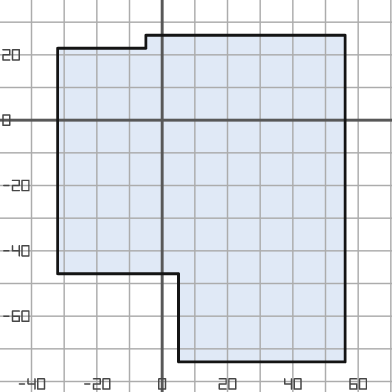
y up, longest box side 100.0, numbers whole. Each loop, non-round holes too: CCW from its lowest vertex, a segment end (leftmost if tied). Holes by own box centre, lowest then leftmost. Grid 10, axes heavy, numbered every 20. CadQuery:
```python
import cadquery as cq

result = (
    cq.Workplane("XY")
    .moveTo(5.0, -74.0)
    .lineTo(56.0, -74.0)
    .lineTo(56.0, 26.0)
    .lineTo(-5.0, 26.0)
    .lineTo(-5.0, 22.0)
    .lineTo(-32.0, 22.0)
    .lineTo(-32.0, -47.0)
    .lineTo(5.0, -47.0)
    .close()
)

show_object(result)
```